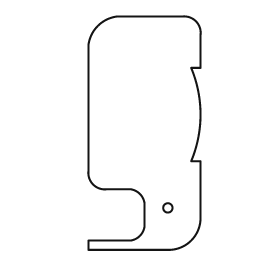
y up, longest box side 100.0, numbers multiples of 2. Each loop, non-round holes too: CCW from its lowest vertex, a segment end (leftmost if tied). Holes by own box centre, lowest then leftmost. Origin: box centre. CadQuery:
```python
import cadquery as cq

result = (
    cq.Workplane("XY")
    .moveTo(-24.0, -50.0)
    .lineTo(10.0, -50.0)
    .threePointArc((20.0, -46.0), (24.0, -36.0))
    .lineTo(24.0, -12.0)
    .lineTo(20.0, -12.0)
    .threePointArc((24.0, 8.0), (20.0, 28.0))
    .lineTo(24.0, 28.0)
    .lineTo(24.0, 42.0)
    .threePointArc((22.0, 48.0), (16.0, 50.0))
    .lineTo(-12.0, 50.0)
    .threePointArc((-20.0, 46.0), (-24.0, 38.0))
    .lineTo(-24.0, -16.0)
    .threePointArc((-22.0, -22.0), (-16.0, -24.0))
    .lineTo(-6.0, -24.0)
    .threePointArc((-2.0, -26.0), (0.0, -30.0))
    .lineTo(0.0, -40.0)
    .threePointArc((-2.0, -44.0), (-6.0, -46.0))
    .lineTo(-24.0, -46.0)
    .close()
    .moveTo(10.0, -32.0)
    .circle(2.0)
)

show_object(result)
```